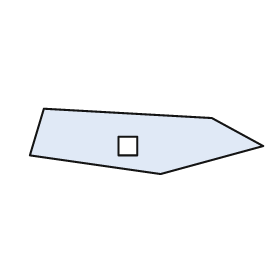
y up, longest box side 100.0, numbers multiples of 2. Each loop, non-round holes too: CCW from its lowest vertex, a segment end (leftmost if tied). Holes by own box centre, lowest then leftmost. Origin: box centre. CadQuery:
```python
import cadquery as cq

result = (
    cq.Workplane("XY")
    .moveTo(6.0, -14.0)
    .lineTo(50.0, -2.0)
    .lineTo(28.0, 10.0)
    .lineTo(-44.0, 14.0)
    .lineTo(-50.0, -6.0)
    .close()
    .moveTo(-12.0, -6.0)
    .lineTo(-4.0, -6.0)
    .lineTo(-4.0, 2.0)
    .lineTo(-12.0, 2.0)
    .close()
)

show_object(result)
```